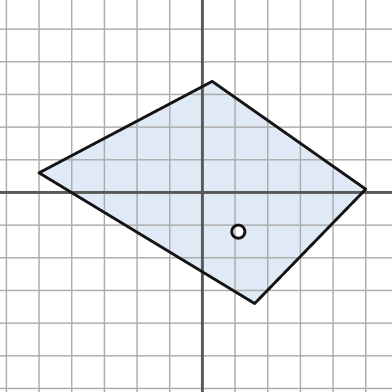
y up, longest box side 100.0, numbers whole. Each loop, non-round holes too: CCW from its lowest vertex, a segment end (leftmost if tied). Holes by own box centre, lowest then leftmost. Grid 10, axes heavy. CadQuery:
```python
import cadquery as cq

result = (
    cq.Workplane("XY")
    .moveTo(16.0, -34.0)
    .lineTo(50.0, 1.0)
    .lineTo(3.0, 34.0)
    .lineTo(-50.0, 6.0)
    .close()
    .moveTo(11.0, -12.0)
    .circle(2.0)
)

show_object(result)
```